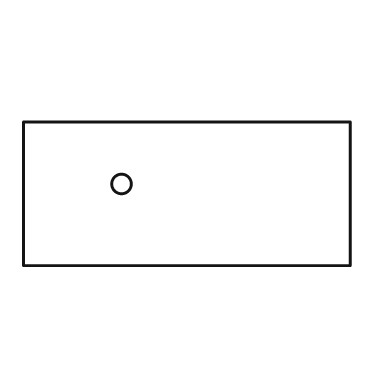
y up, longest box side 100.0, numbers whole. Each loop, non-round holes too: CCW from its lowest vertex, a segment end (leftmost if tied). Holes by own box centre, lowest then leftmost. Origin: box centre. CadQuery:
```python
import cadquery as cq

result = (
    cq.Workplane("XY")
    .moveTo(-50.0, -22.0)
    .lineTo(50.0, -22.0)
    .lineTo(50.0, 22.0)
    .lineTo(-50.0, 22.0)
    .close()
    .moveTo(-20.0, 3.0)
    .circle(3.0)
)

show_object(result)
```